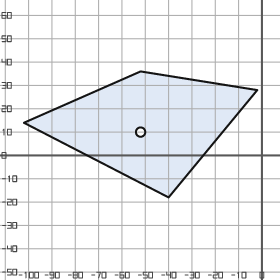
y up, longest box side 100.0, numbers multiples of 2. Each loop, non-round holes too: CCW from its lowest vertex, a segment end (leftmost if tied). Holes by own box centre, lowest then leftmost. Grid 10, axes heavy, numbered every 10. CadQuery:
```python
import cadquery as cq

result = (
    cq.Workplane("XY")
    .moveTo(-40.0, -18.0)
    .lineTo(-2.0, 28.0)
    .lineTo(-52.0, 36.0)
    .lineTo(-102.0, 14.0)
    .close()
    .moveTo(-52.0, 10.0)
    .circle(2.0)
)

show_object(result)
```